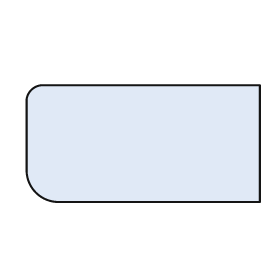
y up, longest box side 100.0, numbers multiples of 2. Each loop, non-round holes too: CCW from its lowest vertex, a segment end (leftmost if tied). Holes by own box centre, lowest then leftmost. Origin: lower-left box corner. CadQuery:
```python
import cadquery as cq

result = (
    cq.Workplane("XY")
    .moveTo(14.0, 0.0)
    .lineTo(100.0, 0.0)
    .lineTo(100.0, 50.0)
    .lineTo(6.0, 50.0)
    .threePointArc((2.0, 48.0), (0.0, 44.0))
    .lineTo(0.0, 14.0)
    .threePointArc((4.0, 4.0), (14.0, 0.0))
    .close()
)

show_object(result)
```